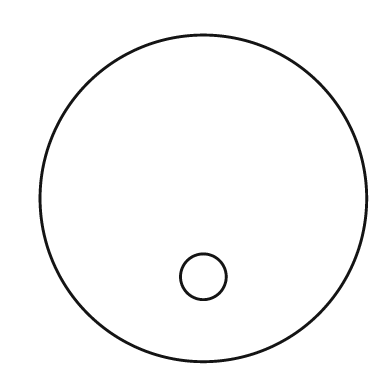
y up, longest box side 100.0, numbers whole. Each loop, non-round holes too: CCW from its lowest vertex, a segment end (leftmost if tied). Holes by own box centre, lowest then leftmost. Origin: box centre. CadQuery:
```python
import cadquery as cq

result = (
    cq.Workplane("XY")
    .moveTo(0.0, 0.0)
    .circle(50.0)
    .moveTo(0.0, -24.0)
    .circle(7.0)
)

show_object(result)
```